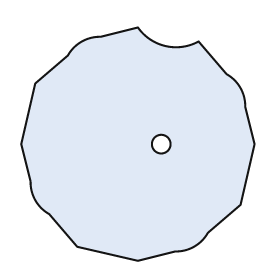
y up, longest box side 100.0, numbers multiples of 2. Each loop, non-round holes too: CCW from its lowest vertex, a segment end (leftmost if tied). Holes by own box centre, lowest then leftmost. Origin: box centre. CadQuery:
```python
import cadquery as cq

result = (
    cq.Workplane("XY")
    .moveTo(0.0, -50.0)
    .lineTo(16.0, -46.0)
    .threePointArc((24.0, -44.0), (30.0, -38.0))
    .lineTo(44.0, -26.0)
    .lineTo(50.0, 0.0)
    .lineTo(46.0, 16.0)
    .threePointArc((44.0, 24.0), (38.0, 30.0))
    .lineTo(26.0, 44.0)
    .threePointArc((12.0, 42.0), (0.0, 50.0))
    .lineTo(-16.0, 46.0)
    .threePointArc((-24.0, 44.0), (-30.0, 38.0))
    .lineTo(-44.0, 26.0)
    .lineTo(-50.0, 0.0)
    .lineTo(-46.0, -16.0)
    .threePointArc((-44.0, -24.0), (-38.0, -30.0))
    .lineTo(-26.0, -44.0)
    .close()
    .moveTo(10.0, 0.0)
    .circle(4.0)
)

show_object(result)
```